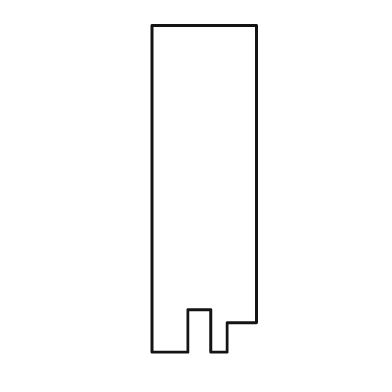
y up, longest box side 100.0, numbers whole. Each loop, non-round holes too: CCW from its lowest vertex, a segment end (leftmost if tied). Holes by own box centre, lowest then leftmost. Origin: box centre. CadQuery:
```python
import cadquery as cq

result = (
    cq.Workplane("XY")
    .moveTo(-16.0, -50.0)
    .lineTo(-5.0, -50.0)
    .lineTo(-5.0, -37.0)
    .lineTo(2.0, -37.0)
    .lineTo(2.0, -50.0)
    .lineTo(7.0, -50.0)
    .lineTo(7.0, -41.0)
    .lineTo(16.0, -41.0)
    .lineTo(16.0, 50.0)
    .lineTo(-16.0, 50.0)
    .close()
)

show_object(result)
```